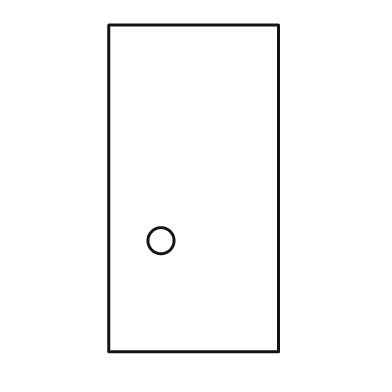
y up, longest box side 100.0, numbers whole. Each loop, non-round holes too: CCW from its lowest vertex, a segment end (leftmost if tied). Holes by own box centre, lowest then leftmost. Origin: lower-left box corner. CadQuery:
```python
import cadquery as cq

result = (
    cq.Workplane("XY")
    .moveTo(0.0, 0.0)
    .lineTo(52.0, 0.0)
    .lineTo(52.0, 100.0)
    .lineTo(0.0, 100.0)
    .close()
    .moveTo(16.0, 34.0)
    .circle(4.0)
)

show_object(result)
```